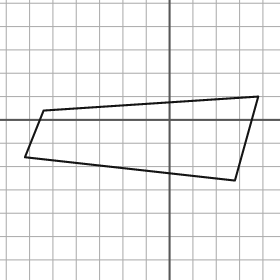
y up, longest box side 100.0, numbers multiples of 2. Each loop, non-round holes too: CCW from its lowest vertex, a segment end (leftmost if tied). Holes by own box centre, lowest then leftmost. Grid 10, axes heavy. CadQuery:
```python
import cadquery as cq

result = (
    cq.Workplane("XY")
    .moveTo(28.0, -26.0)
    .lineTo(38.0, 10.0)
    .lineTo(-54.0, 4.0)
    .lineTo(-62.0, -16.0)
    .close()
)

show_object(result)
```